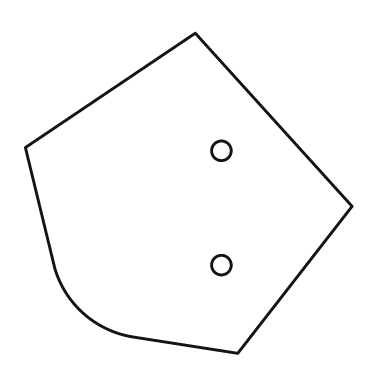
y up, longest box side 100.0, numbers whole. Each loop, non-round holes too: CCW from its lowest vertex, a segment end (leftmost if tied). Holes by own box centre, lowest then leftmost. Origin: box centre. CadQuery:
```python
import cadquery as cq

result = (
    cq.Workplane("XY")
    .moveTo(15.0, -49.0)
    .lineTo(50.0, -4.0)
    .lineTo(2.0, 49.0)
    .lineTo(-50.0, 14.0)
    .lineTo(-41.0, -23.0)
    .threePointArc((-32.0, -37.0), (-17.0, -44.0))
    .close()
    .moveTo(10.0, -22.0)
    .circle(3.0)
    .moveTo(10.0, 13.0)
    .circle(3.0)
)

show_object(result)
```